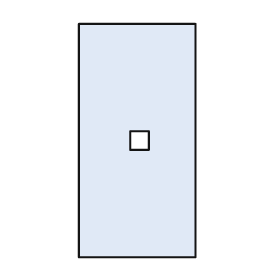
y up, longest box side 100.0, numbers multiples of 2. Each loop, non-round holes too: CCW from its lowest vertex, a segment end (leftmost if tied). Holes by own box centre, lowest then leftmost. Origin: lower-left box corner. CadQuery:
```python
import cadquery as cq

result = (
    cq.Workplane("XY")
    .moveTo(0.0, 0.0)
    .lineTo(50.0, 0.0)
    .lineTo(50.0, 100.0)
    .lineTo(0.0, 100.0)
    .close()
    .moveTo(22.0, 46.0)
    .lineTo(30.0, 46.0)
    .lineTo(30.0, 54.0)
    .lineTo(22.0, 54.0)
    .close()
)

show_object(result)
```